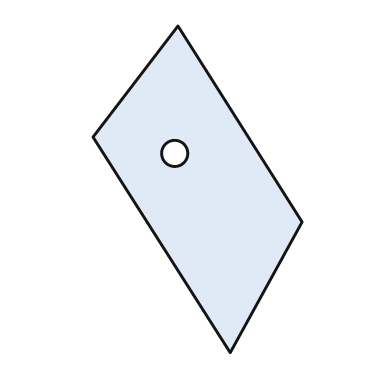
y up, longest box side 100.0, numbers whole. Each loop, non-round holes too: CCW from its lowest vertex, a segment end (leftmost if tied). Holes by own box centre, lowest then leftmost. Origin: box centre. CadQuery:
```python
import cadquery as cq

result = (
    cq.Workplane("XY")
    .moveTo(10.0, -50.0)
    .lineTo(32.0, -10.0)
    .lineTo(-6.0, 50.0)
    .lineTo(-32.0, 16.0)
    .close()
    .moveTo(-7.0, 11.0)
    .circle(4.0)
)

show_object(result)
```